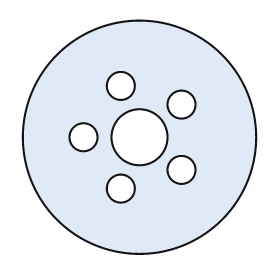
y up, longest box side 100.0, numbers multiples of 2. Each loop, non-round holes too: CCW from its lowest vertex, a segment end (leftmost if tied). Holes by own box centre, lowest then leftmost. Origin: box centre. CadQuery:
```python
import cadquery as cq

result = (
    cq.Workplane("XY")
    .moveTo(0.0, 0.0)
    .circle(50.0)
    .moveTo(-8.0, -22.0)
    .circle(6.0)
    .moveTo(18.0, -14.0)
    .circle(6.0)
    .moveTo(-24.0, 0.0)
    .circle(6.0)
    .moveTo(0.0, 0.0)
    .circle(12.0)
    .moveTo(18.0, 14.0)
    .circle(6.0)
    .moveTo(-8.0, 22.0)
    .circle(6.0)
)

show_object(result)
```